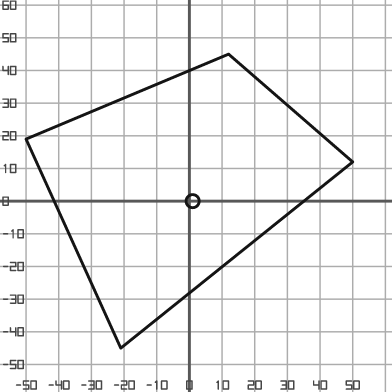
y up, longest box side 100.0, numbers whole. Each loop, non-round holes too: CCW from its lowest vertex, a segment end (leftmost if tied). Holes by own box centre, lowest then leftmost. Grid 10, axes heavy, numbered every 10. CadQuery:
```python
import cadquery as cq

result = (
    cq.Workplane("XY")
    .moveTo(-21.0, -45.0)
    .lineTo(50.0, 12.0)
    .lineTo(12.0, 45.0)
    .lineTo(-50.0, 19.0)
    .close()
    .moveTo(1.0, 0.0)
    .circle(2.0)
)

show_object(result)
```